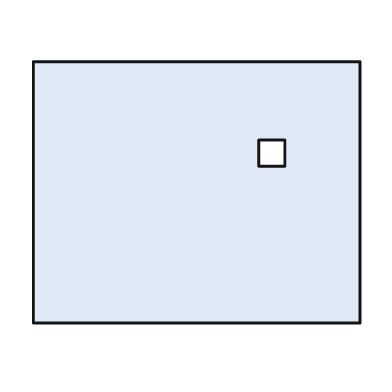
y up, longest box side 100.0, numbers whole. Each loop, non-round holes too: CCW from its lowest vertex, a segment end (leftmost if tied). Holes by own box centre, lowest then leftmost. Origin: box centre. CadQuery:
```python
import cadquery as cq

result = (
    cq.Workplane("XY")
    .moveTo(-50.0, -40.0)
    .lineTo(50.0, -40.0)
    .lineTo(50.0, 40.0)
    .lineTo(-50.0, 40.0)
    .close()
    .moveTo(19.0, 8.0)
    .lineTo(27.0, 8.0)
    .lineTo(27.0, 16.0)
    .lineTo(19.0, 16.0)
    .close()
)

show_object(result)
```